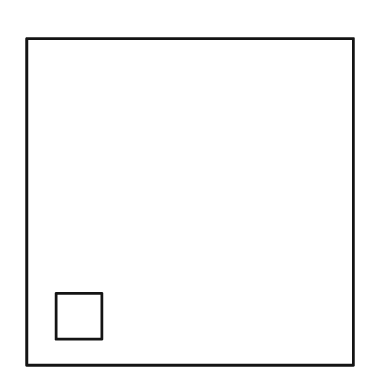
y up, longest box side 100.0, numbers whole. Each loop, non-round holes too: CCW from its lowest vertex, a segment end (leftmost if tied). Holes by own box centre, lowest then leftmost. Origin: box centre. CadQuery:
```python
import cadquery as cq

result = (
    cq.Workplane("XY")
    .moveTo(-50.0, -50.0)
    .lineTo(50.0, -50.0)
    .lineTo(50.0, 50.0)
    .lineTo(-50.0, 50.0)
    .close()
    .moveTo(-41.0, -42.0)
    .lineTo(-27.0, -42.0)
    .lineTo(-27.0, -28.0)
    .lineTo(-41.0, -28.0)
    .close()
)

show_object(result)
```